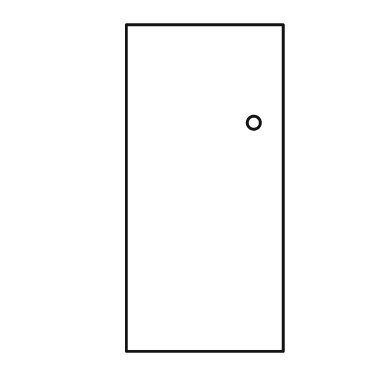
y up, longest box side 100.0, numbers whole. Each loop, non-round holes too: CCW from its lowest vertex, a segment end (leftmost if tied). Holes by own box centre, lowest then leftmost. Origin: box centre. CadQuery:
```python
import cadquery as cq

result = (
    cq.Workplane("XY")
    .moveTo(-24.0, -50.0)
    .lineTo(24.0, -50.0)
    .lineTo(24.0, 50.0)
    .lineTo(-24.0, 50.0)
    .close()
    .moveTo(15.0, 20.0)
    .circle(2.0)
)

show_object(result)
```